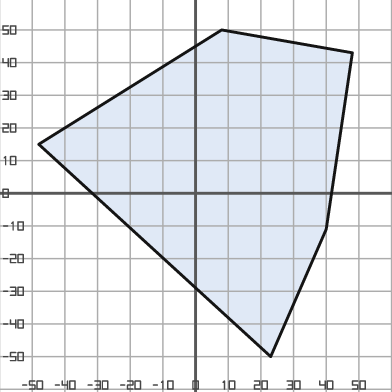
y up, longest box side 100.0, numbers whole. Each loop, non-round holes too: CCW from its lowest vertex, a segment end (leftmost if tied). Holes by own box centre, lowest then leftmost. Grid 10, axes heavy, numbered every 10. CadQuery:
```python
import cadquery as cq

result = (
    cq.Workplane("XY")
    .moveTo(23.0, -50.0)
    .lineTo(40.0, -11.0)
    .lineTo(48.0, 43.0)
    .lineTo(8.0, 50.0)
    .lineTo(-48.0, 15.0)
    .close()
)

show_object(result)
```